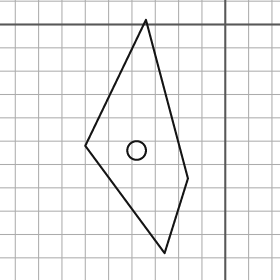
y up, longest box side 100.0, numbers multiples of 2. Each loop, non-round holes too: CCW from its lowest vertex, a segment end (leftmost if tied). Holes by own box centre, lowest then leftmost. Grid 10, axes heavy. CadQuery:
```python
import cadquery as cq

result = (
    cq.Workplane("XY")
    .moveTo(-26.0, -98.0)
    .lineTo(-16.0, -66.0)
    .lineTo(-34.0, 2.0)
    .lineTo(-60.0, -52.0)
    .close()
    .moveTo(-38.0, -54.0)
    .circle(4.0)
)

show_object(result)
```